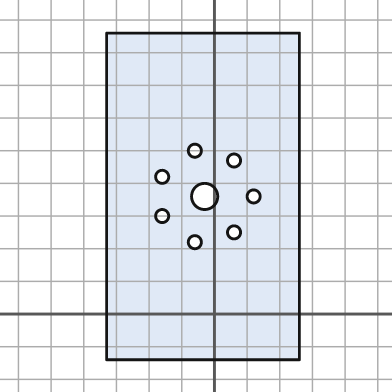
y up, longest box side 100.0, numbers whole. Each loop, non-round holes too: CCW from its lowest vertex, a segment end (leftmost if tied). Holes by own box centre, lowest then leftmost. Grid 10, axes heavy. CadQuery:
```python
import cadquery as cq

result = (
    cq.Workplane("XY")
    .moveTo(-33.0, -14.0)
    .lineTo(26.0, -14.0)
    .lineTo(26.0, 86.0)
    .lineTo(-33.0, 86.0)
    .close()
    .moveTo(-6.0, 22.0)
    .circle(2.0)
    .moveTo(6.0, 25.0)
    .circle(2.0)
    .moveTo(-16.0, 30.0)
    .circle(2.0)
    .moveTo(-3.0, 36.0)
    .circle(4.0)
    .moveTo(12.0, 36.0)
    .circle(2.0)
    .moveTo(-16.0, 42.0)
    .circle(2.0)
    .moveTo(6.0, 47.0)
    .circle(2.0)
    .moveTo(-6.0, 50.0)
    .circle(2.0)
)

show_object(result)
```